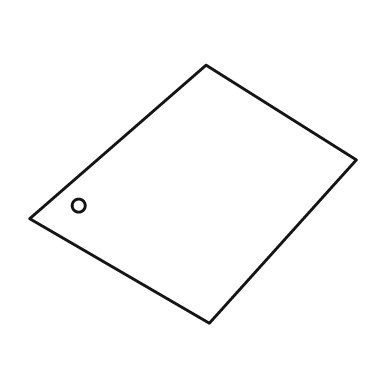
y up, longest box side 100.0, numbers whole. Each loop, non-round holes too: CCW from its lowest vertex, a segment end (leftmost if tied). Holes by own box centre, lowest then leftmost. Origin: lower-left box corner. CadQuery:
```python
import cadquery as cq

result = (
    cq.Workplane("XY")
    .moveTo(55.0, 0.0)
    .lineTo(100.0, 50.0)
    .lineTo(54.0, 79.0)
    .lineTo(0.0, 32.0)
    .close()
    .moveTo(15.0, 36.0)
    .circle(2.0)
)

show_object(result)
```